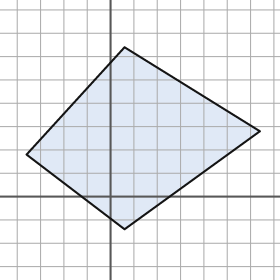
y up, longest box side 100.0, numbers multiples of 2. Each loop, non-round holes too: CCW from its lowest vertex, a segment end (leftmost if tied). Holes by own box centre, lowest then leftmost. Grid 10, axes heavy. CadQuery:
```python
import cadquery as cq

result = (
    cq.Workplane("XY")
    .moveTo(6.0, -14.0)
    .lineTo(64.0, 28.0)
    .lineTo(6.0, 64.0)
    .lineTo(-36.0, 18.0)
    .close()
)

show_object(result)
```